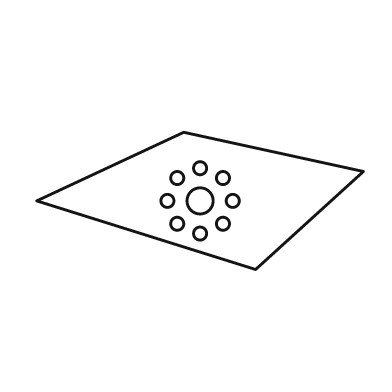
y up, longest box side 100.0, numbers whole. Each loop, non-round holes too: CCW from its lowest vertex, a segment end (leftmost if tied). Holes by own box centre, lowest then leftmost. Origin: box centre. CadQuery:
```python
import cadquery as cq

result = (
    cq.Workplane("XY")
    .moveTo(17.0, -21.0)
    .lineTo(50.0, 9.0)
    .lineTo(-5.0, 21.0)
    .lineTo(-50.0, 0.0)
    .close()
    .moveTo(0.0, -10.0)
    .circle(2.0)
    .moveTo(-7.0, -7.0)
    .circle(2.0)
    .moveTo(7.0, -7.0)
    .circle(2.0)
    .moveTo(-10.0, 0.0)
    .circle(2.0)
    .moveTo(0.0, 0.0)
    .circle(4.0)
    .moveTo(10.0, 0.0)
    .circle(2.0)
    .moveTo(-7.0, 7.0)
    .circle(2.0)
    .moveTo(7.0, 7.0)
    .circle(2.0)
    .moveTo(0.0, 10.0)
    .circle(2.0)
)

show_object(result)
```